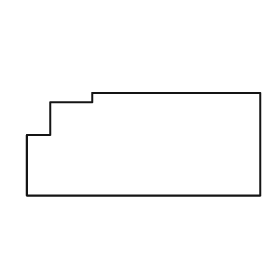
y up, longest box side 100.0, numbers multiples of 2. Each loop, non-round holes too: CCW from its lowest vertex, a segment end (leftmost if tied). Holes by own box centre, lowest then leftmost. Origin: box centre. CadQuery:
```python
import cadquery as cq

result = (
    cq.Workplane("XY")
    .moveTo(-50.0, -22.0)
    .lineTo(50.0, -22.0)
    .lineTo(50.0, 22.0)
    .lineTo(-22.0, 22.0)
    .lineTo(-22.0, 18.0)
    .lineTo(-40.0, 18.0)
    .lineTo(-40.0, 4.0)
    .lineTo(-50.0, 4.0)
    .close()
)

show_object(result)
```